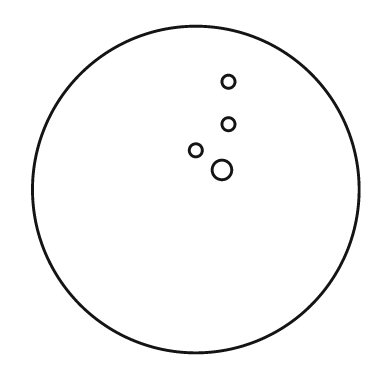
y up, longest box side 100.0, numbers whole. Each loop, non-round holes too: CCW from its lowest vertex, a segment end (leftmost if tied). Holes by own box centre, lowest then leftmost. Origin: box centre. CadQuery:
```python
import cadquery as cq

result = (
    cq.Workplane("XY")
    .moveTo(0.0, 0.0)
    .circle(50.0)
    .moveTo(8.0, 6.0)
    .circle(3.0)
    .moveTo(0.0, 12.0)
    .circle(2.0)
    .moveTo(10.0, 20.0)
    .circle(2.0)
    .moveTo(10.0, 33.0)
    .circle(2.0)
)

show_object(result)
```